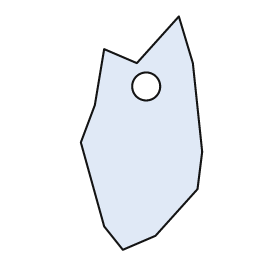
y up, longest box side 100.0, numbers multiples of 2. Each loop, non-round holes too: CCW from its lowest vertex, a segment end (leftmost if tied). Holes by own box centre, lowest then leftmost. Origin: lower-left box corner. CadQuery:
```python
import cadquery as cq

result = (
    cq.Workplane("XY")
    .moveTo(18.0, 0.0)
    .lineTo(32.0, 6.0)
    .lineTo(50.0, 26.0)
    .lineTo(52.0, 42.0)
    .lineTo(48.0, 80.0)
    .lineTo(42.0, 100.0)
    .lineTo(24.0, 80.0)
    .lineTo(10.0, 86.0)
    .lineTo(6.0, 62.0)
    .lineTo(0.0, 46.0)
    .lineTo(10.0, 10.0)
    .close()
    .moveTo(28.0, 70.0)
    .circle(6.0)
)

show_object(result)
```